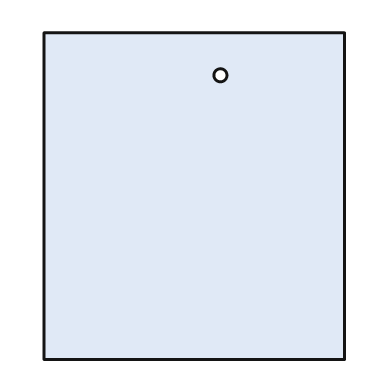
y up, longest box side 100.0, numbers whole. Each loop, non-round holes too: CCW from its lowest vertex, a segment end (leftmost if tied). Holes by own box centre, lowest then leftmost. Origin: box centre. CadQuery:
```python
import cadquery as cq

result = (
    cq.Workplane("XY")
    .moveTo(-46.0, -50.0)
    .lineTo(46.0, -50.0)
    .lineTo(46.0, 50.0)
    .lineTo(-46.0, 50.0)
    .close()
    .moveTo(8.0, 37.0)
    .circle(2.0)
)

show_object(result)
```